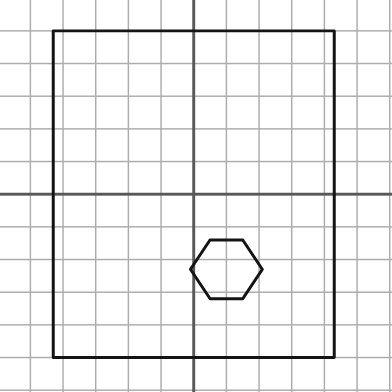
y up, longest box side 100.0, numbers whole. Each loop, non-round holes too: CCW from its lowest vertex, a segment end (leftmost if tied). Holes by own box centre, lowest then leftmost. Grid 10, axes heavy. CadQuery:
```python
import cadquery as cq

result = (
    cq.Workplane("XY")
    .moveTo(-43.0, -50.0)
    .lineTo(43.0, -50.0)
    .lineTo(43.0, 50.0)
    .lineTo(-43.0, 50.0)
    .close()
    .moveTo(5.0, -32.0)
    .lineTo(15.0, -32.0)
    .lineTo(21.0, -23.0)
    .lineTo(15.0, -14.0)
    .lineTo(5.0, -14.0)
    .lineTo(-1.0, -23.0)
    .close()
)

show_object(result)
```